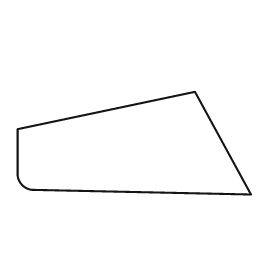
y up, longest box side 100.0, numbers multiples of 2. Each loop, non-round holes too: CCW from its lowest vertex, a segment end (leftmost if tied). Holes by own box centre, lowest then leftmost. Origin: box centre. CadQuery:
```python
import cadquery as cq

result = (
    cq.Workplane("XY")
    .moveTo(50.0, -22.0)
    .lineTo(26.0, 22.0)
    .lineTo(-50.0, 6.0)
    .lineTo(-50.0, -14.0)
    .threePointArc((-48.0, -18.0), (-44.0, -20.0))
    .close()
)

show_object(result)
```